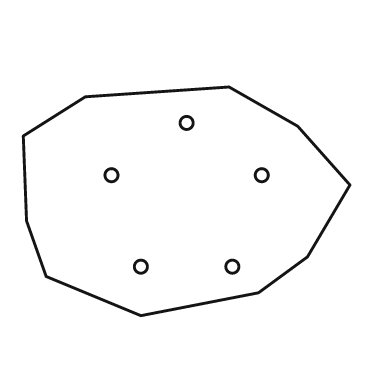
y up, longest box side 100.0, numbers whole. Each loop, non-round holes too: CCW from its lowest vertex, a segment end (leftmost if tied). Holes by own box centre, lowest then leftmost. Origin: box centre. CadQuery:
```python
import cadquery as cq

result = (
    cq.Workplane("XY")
    .moveTo(-14.0, -35.0)
    .lineTo(22.0, -28.0)
    .lineTo(37.0, -17.0)
    .lineTo(50.0, 5.0)
    .lineTo(34.0, 23.0)
    .lineTo(13.0, 35.0)
    .lineTo(-31.0, 32.0)
    .lineTo(-50.0, 20.0)
    .lineTo(-49.0, -6.0)
    .lineTo(-43.0, -23.0)
    .close()
    .moveTo(-14.0, -20.0)
    .circle(2.0)
    .moveTo(14.0, -20.0)
    .circle(2.0)
    .moveTo(-23.0, 8.0)
    .circle(2.0)
    .moveTo(23.0, 8.0)
    .circle(2.0)
    .moveTo(0.0, 24.0)
    .circle(2.0)
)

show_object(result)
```